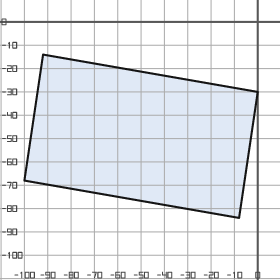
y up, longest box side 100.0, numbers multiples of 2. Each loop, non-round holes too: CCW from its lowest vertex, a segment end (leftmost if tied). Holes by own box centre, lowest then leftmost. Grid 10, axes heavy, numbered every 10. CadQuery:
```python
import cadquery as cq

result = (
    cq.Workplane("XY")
    .moveTo(-8.0, -84.0)
    .lineTo(0.0, -30.0)
    .lineTo(-92.0, -14.0)
    .lineTo(-100.0, -68.0)
    .close()
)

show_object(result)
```